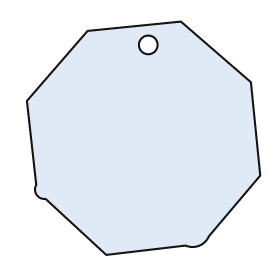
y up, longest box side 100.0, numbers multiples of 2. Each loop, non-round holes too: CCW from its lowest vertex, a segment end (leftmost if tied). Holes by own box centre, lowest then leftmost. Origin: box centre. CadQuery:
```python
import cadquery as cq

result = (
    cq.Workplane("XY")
    .moveTo(-16.0, -50.0)
    .lineTo(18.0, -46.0)
    .threePointArc((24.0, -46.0), (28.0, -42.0))
    .lineTo(50.0, -16.0)
    .lineTo(46.0, 24.0)
    .lineTo(16.0, 50.0)
    .lineTo(-24.0, 46.0)
    .lineTo(-50.0, 16.0)
    .lineTo(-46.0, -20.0)
    .threePointArc((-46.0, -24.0), (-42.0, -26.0))
    .close()
    .moveTo(2.0, 40.0)
    .circle(4.0)
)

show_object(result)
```